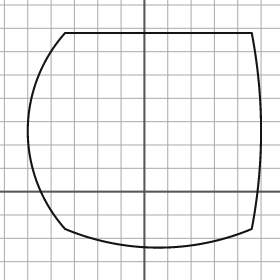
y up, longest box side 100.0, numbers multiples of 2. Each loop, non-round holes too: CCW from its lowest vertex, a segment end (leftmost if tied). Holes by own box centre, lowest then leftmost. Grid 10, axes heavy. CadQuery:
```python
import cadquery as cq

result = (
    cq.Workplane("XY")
    .moveTo(-34.0, -16.0)
    .threePointArc((6.0, -24.0), (46.0, -16.0))
    .threePointArc((50.0, 26.0), (46.0, 68.0))
    .lineTo(-34.0, 68.0)
    .threePointArc((-50.0, 26.0), (-34.0, -16.0))
    .close()
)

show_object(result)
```